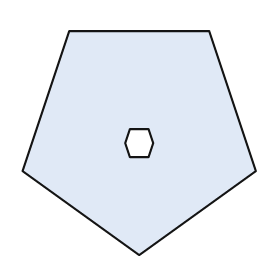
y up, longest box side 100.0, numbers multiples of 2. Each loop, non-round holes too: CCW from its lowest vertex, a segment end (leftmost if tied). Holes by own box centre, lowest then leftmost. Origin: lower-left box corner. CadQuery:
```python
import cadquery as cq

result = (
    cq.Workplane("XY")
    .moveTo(50.0, 0.0)
    .lineTo(100.0, 36.0)
    .lineTo(80.0, 96.0)
    .lineTo(20.0, 96.0)
    .lineTo(0.0, 36.0)
    .close()
    .moveTo(46.0, 42.0)
    .lineTo(54.0, 42.0)
    .lineTo(56.0, 48.0)
    .lineTo(54.0, 54.0)
    .lineTo(46.0, 54.0)
    .lineTo(44.0, 48.0)
    .close()
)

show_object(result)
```